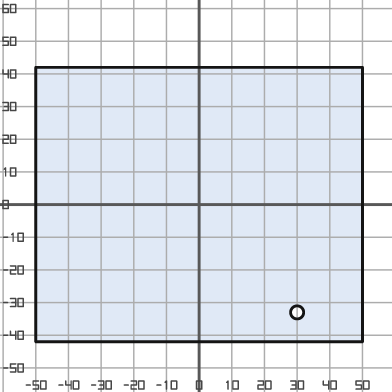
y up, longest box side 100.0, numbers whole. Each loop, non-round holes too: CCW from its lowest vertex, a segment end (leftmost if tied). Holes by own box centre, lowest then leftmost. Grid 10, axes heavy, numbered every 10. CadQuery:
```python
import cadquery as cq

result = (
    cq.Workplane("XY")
    .moveTo(-50.0, -42.0)
    .lineTo(50.0, -42.0)
    .lineTo(50.0, 42.0)
    .lineTo(-50.0, 42.0)
    .close()
    .moveTo(30.0, -33.0)
    .circle(2.0)
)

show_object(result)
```